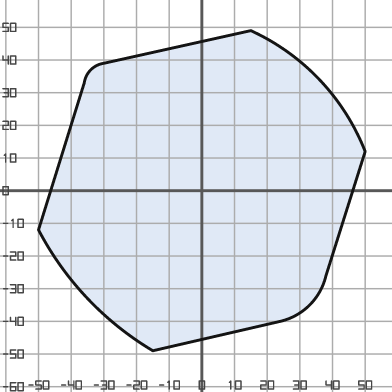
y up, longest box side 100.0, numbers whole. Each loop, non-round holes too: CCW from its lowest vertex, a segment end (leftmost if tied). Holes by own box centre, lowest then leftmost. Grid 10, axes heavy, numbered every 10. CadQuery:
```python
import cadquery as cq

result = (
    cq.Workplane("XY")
    .moveTo(-15.0, -49.0)
    .lineTo(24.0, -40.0)
    .threePointArc((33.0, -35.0), (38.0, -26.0))
    .lineTo(50.0, 12.0)
    .threePointArc((36.0, 34.0), (15.0, 49.0))
    .lineTo(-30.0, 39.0)
    .threePointArc((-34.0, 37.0), (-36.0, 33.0))
    .lineTo(-50.0, -12.0)
    .threePointArc((-35.0, -33.0), (-15.0, -49.0))
    .close()
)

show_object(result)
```